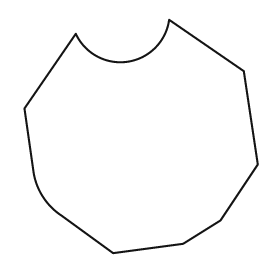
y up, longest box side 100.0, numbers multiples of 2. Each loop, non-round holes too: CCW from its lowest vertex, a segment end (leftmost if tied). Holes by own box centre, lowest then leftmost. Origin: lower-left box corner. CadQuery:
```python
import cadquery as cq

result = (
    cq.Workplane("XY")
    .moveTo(38.0, 0.0)
    .lineTo(68.0, 4.0)
    .lineTo(84.0, 14.0)
    .lineTo(100.0, 38.0)
    .lineTo(94.0, 78.0)
    .lineTo(62.0, 100.0)
    .threePointArc((44.0, 82.0), (22.0, 94.0))
    .lineTo(0.0, 62.0)
    .lineTo(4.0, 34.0)
    .threePointArc((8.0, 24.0), (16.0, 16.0))
    .close()
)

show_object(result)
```